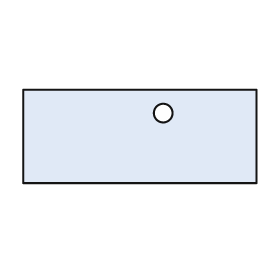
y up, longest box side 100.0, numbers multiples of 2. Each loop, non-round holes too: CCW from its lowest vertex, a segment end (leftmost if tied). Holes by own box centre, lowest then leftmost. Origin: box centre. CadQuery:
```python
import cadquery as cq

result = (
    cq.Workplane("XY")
    .moveTo(-50.0, -20.0)
    .lineTo(50.0, -20.0)
    .lineTo(50.0, 20.0)
    .lineTo(-50.0, 20.0)
    .close()
    .moveTo(10.0, 10.0)
    .circle(4.0)
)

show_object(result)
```